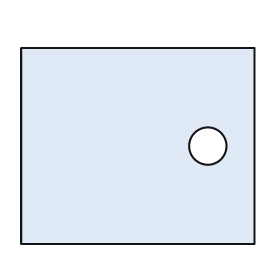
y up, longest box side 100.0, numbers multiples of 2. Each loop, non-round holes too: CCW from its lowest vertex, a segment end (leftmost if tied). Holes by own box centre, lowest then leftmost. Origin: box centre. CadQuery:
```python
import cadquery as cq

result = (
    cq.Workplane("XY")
    .moveTo(-50.0, -42.0)
    .lineTo(50.0, -42.0)
    .lineTo(50.0, 42.0)
    .lineTo(-50.0, 42.0)
    .close()
    .moveTo(30.0, 0.0)
    .circle(8.0)
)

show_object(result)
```